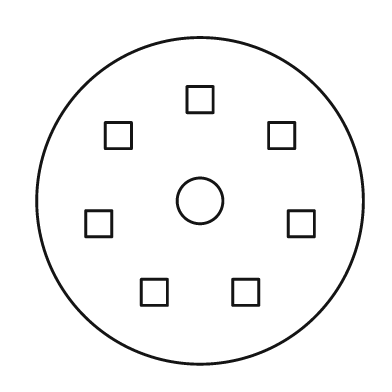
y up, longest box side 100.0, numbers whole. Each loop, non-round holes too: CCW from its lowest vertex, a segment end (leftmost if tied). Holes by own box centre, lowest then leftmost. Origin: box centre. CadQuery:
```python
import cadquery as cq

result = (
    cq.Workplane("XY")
    .moveTo(0.0, 0.0)
    .circle(50.0)
    .moveTo(-18.0, -32.0)
    .lineTo(-10.0, -32.0)
    .lineTo(-10.0, -24.0)
    .lineTo(-18.0, -24.0)
    .close()
    .moveTo(10.0, -32.0)
    .lineTo(18.0, -32.0)
    .lineTo(18.0, -24.0)
    .lineTo(10.0, -24.0)
    .close()
    .moveTo(-35.0, -11.0)
    .lineTo(-27.0, -11.0)
    .lineTo(-27.0, -3.0)
    .lineTo(-35.0, -3.0)
    .close()
    .moveTo(27.0, -11.0)
    .lineTo(35.0, -11.0)
    .lineTo(35.0, -3.0)
    .lineTo(27.0, -3.0)
    .close()
    .moveTo(0.0, 0.0)
    .circle(7.0)
    .moveTo(-29.0, 16.0)
    .lineTo(-21.0, 16.0)
    .lineTo(-21.0, 24.0)
    .lineTo(-29.0, 24.0)
    .close()
    .moveTo(21.0, 16.0)
    .lineTo(29.0, 16.0)
    .lineTo(29.0, 24.0)
    .lineTo(21.0, 24.0)
    .close()
    .moveTo(-4.0, 27.0)
    .lineTo(4.0, 27.0)
    .lineTo(4.0, 35.0)
    .lineTo(-4.0, 35.0)
    .close()
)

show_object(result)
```